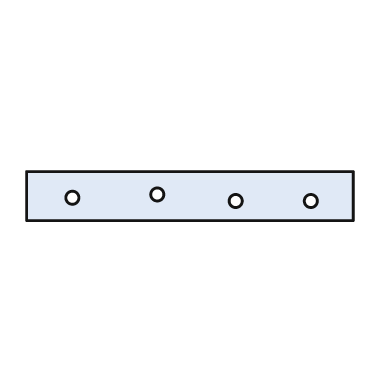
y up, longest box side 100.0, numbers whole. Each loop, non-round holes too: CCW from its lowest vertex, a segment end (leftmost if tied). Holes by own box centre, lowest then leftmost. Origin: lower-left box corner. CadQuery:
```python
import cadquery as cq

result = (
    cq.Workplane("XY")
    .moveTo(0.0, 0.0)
    .lineTo(100.0, 0.0)
    .lineTo(100.0, 15.0)
    .lineTo(0.0, 15.0)
    .close()
    .moveTo(64.0, 6.0)
    .circle(2.0)
    .moveTo(87.0, 6.0)
    .circle(2.0)
    .moveTo(14.0, 7.0)
    .circle(2.0)
    .moveTo(40.0, 8.0)
    .circle(2.0)
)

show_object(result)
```